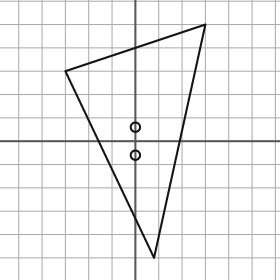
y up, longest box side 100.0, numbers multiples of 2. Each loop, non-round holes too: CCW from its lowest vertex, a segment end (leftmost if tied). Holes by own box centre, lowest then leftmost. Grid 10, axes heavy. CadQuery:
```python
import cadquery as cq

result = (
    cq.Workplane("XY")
    .moveTo(8.0, -50.0)
    .lineTo(30.0, 50.0)
    .lineTo(-30.0, 30.0)
    .close()
    .moveTo(0.0, -6.0)
    .circle(2.0)
    .moveTo(0.0, 6.0)
    .circle(2.0)
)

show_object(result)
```